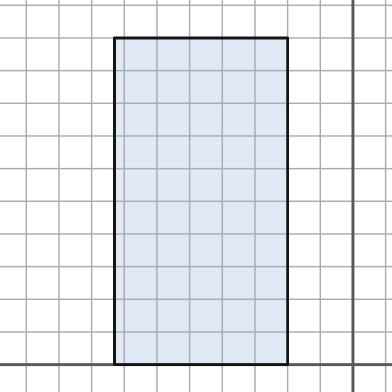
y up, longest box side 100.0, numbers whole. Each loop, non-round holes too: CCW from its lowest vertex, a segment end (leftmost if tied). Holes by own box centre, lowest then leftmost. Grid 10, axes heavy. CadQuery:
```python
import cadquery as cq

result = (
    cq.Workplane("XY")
    .moveTo(-73.0, 0.0)
    .lineTo(-20.0, 0.0)
    .lineTo(-20.0, 100.0)
    .lineTo(-73.0, 100.0)
    .close()
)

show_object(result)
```